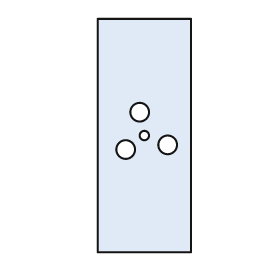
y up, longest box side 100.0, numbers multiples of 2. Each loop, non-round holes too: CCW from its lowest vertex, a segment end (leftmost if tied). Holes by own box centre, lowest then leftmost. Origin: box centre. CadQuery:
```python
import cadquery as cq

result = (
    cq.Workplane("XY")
    .moveTo(-20.0, -50.0)
    .lineTo(20.0, -50.0)
    .lineTo(20.0, 50.0)
    .lineTo(-20.0, 50.0)
    .close()
    .moveTo(-8.0, -6.0)
    .circle(4.0)
    .moveTo(10.0, -4.0)
    .circle(4.0)
    .moveTo(0.0, 0.0)
    .circle(2.0)
    .moveTo(-2.0, 10.0)
    .circle(4.0)
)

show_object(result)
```